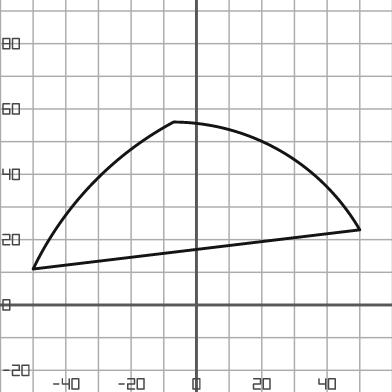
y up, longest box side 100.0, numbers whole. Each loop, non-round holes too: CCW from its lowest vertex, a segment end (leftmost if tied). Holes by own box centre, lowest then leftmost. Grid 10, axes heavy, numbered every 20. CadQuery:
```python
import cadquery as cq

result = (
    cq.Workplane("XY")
    .moveTo(-50.0, 11.0)
    .lineTo(50.0, 23.0)
    .threePointArc((26.0, 47.0), (-7.0, 56.0))
    .threePointArc((-32.0, 37.0), (-50.0, 11.0))
    .close()
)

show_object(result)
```